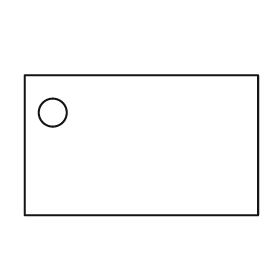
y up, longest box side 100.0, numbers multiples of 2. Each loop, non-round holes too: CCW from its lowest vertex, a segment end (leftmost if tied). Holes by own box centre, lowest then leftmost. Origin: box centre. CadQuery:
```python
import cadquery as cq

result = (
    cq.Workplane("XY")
    .moveTo(-50.0, -30.0)
    .lineTo(50.0, -30.0)
    .lineTo(50.0, 30.0)
    .lineTo(-50.0, 30.0)
    .close()
    .moveTo(-38.0, 14.0)
    .circle(6.0)
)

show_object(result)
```